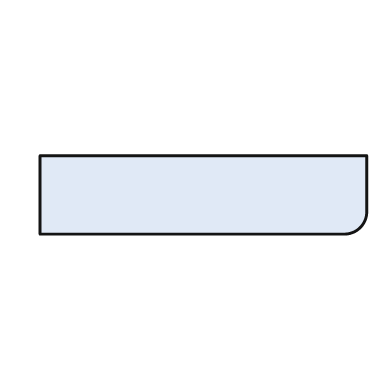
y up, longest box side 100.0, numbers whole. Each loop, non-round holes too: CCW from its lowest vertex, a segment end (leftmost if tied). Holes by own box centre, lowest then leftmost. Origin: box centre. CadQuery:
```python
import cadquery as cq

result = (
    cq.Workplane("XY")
    .moveTo(-50.0, -12.0)
    .lineTo(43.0, -12.0)
    .threePointArc((48.0, -10.0), (50.0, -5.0))
    .lineTo(50.0, 12.0)
    .lineTo(-50.0, 12.0)
    .close()
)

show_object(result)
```